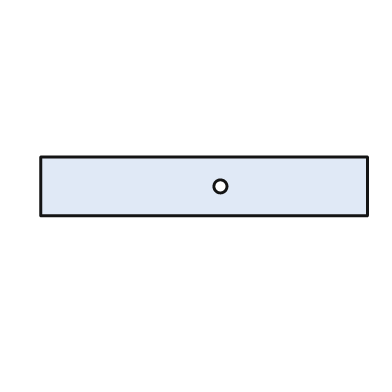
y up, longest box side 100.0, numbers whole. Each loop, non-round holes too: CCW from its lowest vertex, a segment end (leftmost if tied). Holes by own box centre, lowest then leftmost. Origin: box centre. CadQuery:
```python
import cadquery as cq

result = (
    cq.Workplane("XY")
    .moveTo(-50.0, -9.0)
    .lineTo(50.0, -9.0)
    .lineTo(50.0, 9.0)
    .lineTo(-50.0, 9.0)
    .close()
    .moveTo(5.0, 0.0)
    .circle(2.0)
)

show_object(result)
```